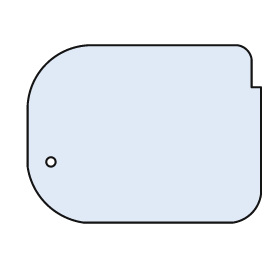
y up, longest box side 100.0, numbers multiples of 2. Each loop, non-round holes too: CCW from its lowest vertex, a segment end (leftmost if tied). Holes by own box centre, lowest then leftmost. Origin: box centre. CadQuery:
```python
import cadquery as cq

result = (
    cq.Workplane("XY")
    .moveTo(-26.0, -38.0)
    .lineTo(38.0, -38.0)
    .threePointArc((46.0, -34.0), (50.0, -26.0))
    .lineTo(50.0, 20.0)
    .lineTo(46.0, 20.0)
    .lineTo(46.0, 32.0)
    .threePointArc((44.0, 36.0), (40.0, 38.0))
    .lineTo(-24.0, 38.0)
    .threePointArc((-42.0, 30.0), (-50.0, 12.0))
    .lineTo(-50.0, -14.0)
    .threePointArc((-42.0, -30.0), (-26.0, -38.0))
    .close()
    .moveTo(-40.0, -12.0)
    .circle(2.0)
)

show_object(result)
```